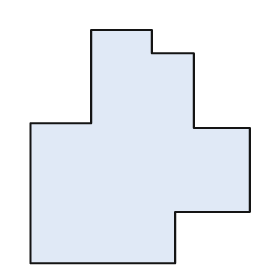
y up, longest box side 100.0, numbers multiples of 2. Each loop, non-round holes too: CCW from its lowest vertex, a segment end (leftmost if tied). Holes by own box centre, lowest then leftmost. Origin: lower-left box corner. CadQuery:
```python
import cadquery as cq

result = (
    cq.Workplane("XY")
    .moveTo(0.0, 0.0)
    .lineTo(62.0, 0.0)
    .lineTo(62.0, 22.0)
    .lineTo(94.0, 22.0)
    .lineTo(94.0, 58.0)
    .lineTo(70.0, 58.0)
    .lineTo(70.0, 90.0)
    .lineTo(52.0, 90.0)
    .lineTo(52.0, 100.0)
    .lineTo(26.0, 100.0)
    .lineTo(26.0, 60.0)
    .lineTo(0.0, 60.0)
    .close()
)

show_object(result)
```